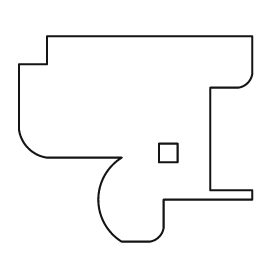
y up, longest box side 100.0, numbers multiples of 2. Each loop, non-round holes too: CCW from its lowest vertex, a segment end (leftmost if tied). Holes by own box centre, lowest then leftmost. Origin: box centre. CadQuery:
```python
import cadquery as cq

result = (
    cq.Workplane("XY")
    .moveTo(-6.0, -44.0)
    .lineTo(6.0, -44.0)
    .threePointArc((10.0, -42.0), (12.0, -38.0))
    .lineTo(12.0, -26.0)
    .lineTo(50.0, -26.0)
    .lineTo(50.0, -22.0)
    .lineTo(32.0, -22.0)
    .lineTo(32.0, 22.0)
    .lineTo(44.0, 22.0)
    .threePointArc((48.0, 24.0), (50.0, 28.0))
    .lineTo(50.0, 44.0)
    .lineTo(-38.0, 44.0)
    .lineTo(-38.0, 32.0)
    .lineTo(-50.0, 32.0)
    .lineTo(-50.0, 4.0)
    .threePointArc((-46.0, -4.0), (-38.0, -8.0))
    .lineTo(-6.0, -8.0)
    .threePointArc((-16.0, -26.0), (-6.0, -44.0))
    .close()
    .moveTo(10.0, -10.0)
    .lineTo(18.0, -10.0)
    .lineTo(18.0, -2.0)
    .lineTo(10.0, -2.0)
    .close()
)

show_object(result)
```